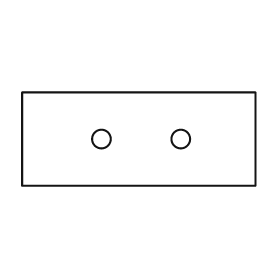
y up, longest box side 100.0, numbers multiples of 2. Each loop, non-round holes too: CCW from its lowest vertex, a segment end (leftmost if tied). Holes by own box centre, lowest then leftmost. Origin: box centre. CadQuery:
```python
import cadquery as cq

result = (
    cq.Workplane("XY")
    .moveTo(-50.0, -20.0)
    .lineTo(50.0, -20.0)
    .lineTo(50.0, 20.0)
    .lineTo(-50.0, 20.0)
    .close()
    .moveTo(-16.0, 0.0)
    .circle(4.0)
    .moveTo(18.0, 0.0)
    .circle(4.0)
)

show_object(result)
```